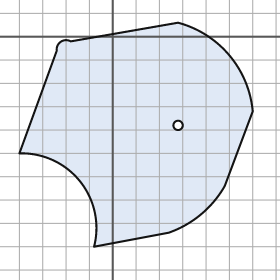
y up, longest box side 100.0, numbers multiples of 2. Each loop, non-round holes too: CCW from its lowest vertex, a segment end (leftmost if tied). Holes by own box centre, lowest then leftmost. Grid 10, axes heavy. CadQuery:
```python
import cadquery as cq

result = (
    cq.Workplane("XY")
    .moveTo(-8.0, -90.0)
    .lineTo(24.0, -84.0)
    .threePointArc((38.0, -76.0), (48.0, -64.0))
    .lineTo(60.0, -32.0)
    .threePointArc((50.0, -8.0), (28.0, 6.0))
    .lineTo(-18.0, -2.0)
    .threePointArc((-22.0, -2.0), (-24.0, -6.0))
    .lineTo(-40.0, -50.0)
    .threePointArc((-14.0, -62.0), (-8.0, -90.0))
    .close()
    .moveTo(28.0, -38.0)
    .circle(2.0)
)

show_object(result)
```